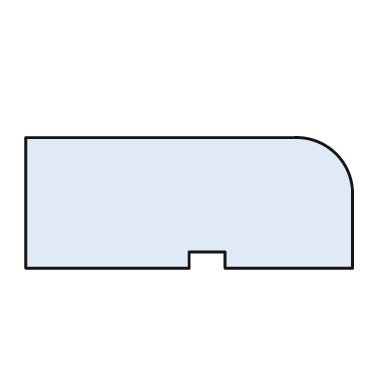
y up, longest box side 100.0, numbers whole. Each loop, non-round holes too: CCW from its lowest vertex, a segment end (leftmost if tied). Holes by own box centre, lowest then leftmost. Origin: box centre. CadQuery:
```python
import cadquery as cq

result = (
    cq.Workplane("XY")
    .moveTo(-50.0, -20.0)
    .lineTo(0.0, -20.0)
    .lineTo(0.0, -15.0)
    .lineTo(11.0, -15.0)
    .lineTo(11.0, -20.0)
    .lineTo(50.0, -20.0)
    .lineTo(50.0, 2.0)
    .threePointArc((45.0, 15.0), (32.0, 20.0))
    .lineTo(-50.0, 20.0)
    .close()
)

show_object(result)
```